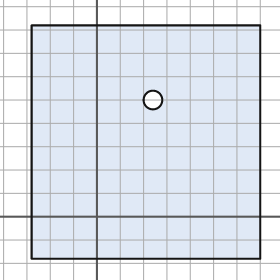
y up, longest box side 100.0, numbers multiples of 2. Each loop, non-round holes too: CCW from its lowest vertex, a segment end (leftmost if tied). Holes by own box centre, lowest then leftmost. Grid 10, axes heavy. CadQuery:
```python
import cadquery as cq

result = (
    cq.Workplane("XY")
    .moveTo(-28.0, -18.0)
    .lineTo(70.0, -18.0)
    .lineTo(70.0, 82.0)
    .lineTo(-28.0, 82.0)
    .close()
    .moveTo(24.0, 50.0)
    .circle(4.0)
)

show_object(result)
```